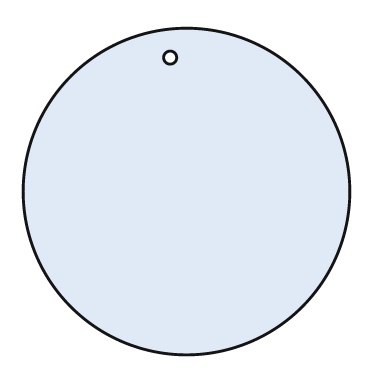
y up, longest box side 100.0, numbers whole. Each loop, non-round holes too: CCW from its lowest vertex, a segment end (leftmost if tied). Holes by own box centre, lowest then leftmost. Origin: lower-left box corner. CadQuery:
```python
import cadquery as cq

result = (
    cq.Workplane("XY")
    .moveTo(50.0, 50.0)
    .circle(50.0)
    .moveTo(45.0, 91.0)
    .circle(2.0)
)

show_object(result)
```